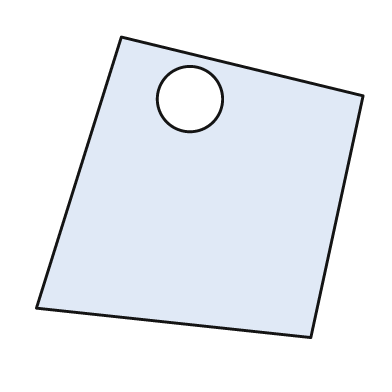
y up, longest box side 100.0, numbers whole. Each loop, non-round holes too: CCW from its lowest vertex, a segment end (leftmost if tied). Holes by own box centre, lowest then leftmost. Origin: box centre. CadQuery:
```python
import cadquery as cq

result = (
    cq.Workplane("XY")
    .moveTo(34.0, -46.0)
    .lineTo(50.0, 28.0)
    .lineTo(-24.0, 46.0)
    .lineTo(-50.0, -37.0)
    .close()
    .moveTo(-3.0, 27.0)
    .circle(10.0)
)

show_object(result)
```